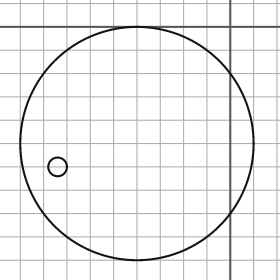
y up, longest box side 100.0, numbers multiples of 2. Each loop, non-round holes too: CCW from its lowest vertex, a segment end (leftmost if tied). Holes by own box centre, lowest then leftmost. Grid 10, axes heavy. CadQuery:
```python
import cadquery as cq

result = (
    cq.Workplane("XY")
    .moveTo(-40.0, -50.0)
    .circle(50.0)
    .moveTo(-74.0, -60.0)
    .circle(4.0)
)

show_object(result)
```